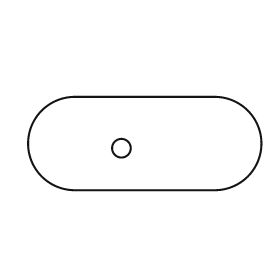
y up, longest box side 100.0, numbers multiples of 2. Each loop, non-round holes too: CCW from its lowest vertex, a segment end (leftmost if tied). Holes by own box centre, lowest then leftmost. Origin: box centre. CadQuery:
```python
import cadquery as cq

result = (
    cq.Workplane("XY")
    .moveTo(-30.0, -20.0)
    .lineTo(30.0, -20.0)
    .threePointArc((50.0, 0.0), (30.0, 20.0))
    .lineTo(-30.0, 20.0)
    .threePointArc((-50.0, 0.0), (-30.0, -20.0))
    .close()
    .moveTo(-10.0, -2.0)
    .circle(4.0)
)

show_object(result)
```